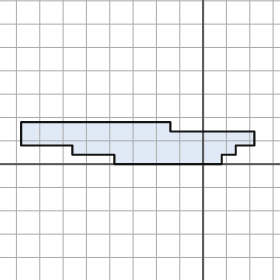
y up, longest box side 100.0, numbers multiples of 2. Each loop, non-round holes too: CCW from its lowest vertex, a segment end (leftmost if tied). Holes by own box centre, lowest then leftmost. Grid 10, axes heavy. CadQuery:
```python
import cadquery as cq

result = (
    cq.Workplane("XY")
    .moveTo(-38.0, 0.0)
    .lineTo(8.0, 0.0)
    .lineTo(8.0, 4.0)
    .lineTo(14.0, 4.0)
    .lineTo(14.0, 8.0)
    .lineTo(22.0, 8.0)
    .lineTo(22.0, 14.0)
    .lineTo(-14.0, 14.0)
    .lineTo(-14.0, 18.0)
    .lineTo(-78.0, 18.0)
    .lineTo(-78.0, 8.0)
    .lineTo(-56.0, 8.0)
    .lineTo(-56.0, 4.0)
    .lineTo(-38.0, 4.0)
    .close()
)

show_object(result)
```